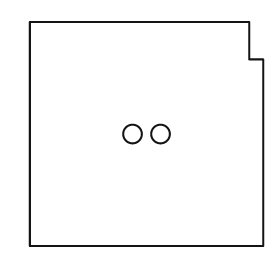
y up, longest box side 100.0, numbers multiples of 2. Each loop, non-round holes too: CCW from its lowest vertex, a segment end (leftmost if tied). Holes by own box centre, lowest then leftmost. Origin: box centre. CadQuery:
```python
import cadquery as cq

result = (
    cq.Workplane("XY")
    .moveTo(-50.0, -48.0)
    .lineTo(50.0, -48.0)
    .lineTo(50.0, 32.0)
    .lineTo(44.0, 32.0)
    .lineTo(44.0, 48.0)
    .lineTo(-50.0, 48.0)
    .close()
    .moveTo(-6.0, 0.0)
    .circle(4.0)
    .moveTo(6.0, 0.0)
    .circle(4.0)
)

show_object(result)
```